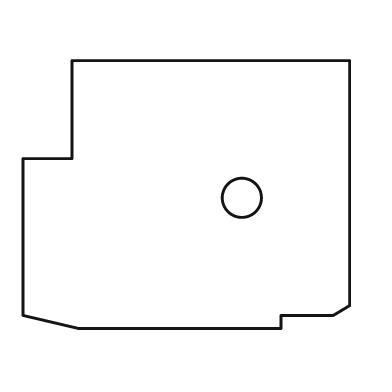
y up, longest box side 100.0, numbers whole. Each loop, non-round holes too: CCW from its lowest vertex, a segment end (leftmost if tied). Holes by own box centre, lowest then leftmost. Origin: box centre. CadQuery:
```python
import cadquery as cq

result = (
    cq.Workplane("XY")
    .moveTo(-33.0, -41.0)
    .lineTo(29.0, -41.0)
    .lineTo(29.0, -37.0)
    .lineTo(45.0, -37.0)
    .lineTo(50.0, -34.0)
    .lineTo(50.0, 41.0)
    .lineTo(-35.0, 41.0)
    .lineTo(-35.0, 11.0)
    .lineTo(-50.0, 11.0)
    .lineTo(-50.0, -37.0)
    .close()
    .moveTo(17.0, -1.0)
    .circle(6.0)
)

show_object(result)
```